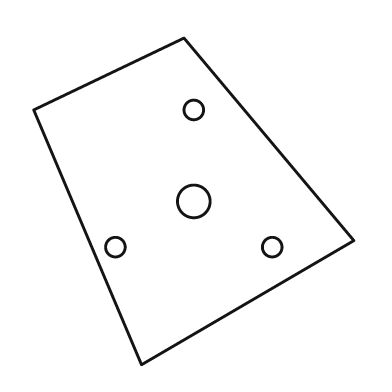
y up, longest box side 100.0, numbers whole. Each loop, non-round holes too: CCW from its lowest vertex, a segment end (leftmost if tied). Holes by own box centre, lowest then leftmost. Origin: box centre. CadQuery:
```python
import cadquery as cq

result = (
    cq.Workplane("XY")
    .moveTo(-16.0, -50.0)
    .lineTo(49.0, -12.0)
    .lineTo(-3.0, 50.0)
    .lineTo(-49.0, 28.0)
    .close()
    .moveTo(-24.0, -14.0)
    .circle(3.0)
    .moveTo(24.0, -14.0)
    .circle(3.0)
    .moveTo(0.0, 0.0)
    .circle(5.0)
    .moveTo(0.0, 28.0)
    .circle(3.0)
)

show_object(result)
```